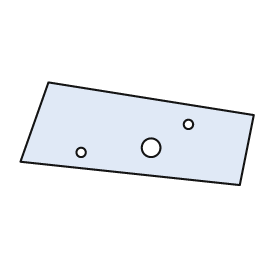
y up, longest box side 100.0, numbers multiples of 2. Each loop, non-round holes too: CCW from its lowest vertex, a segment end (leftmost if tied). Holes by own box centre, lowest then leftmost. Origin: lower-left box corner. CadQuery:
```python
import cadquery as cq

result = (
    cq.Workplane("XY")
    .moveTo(94.0, 0.0)
    .lineTo(100.0, 30.0)
    .lineTo(12.0, 44.0)
    .lineTo(0.0, 10.0)
    .close()
    .moveTo(26.0, 14.0)
    .circle(2.0)
    .moveTo(56.0, 16.0)
    .circle(4.0)
    .moveTo(72.0, 26.0)
    .circle(2.0)
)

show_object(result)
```